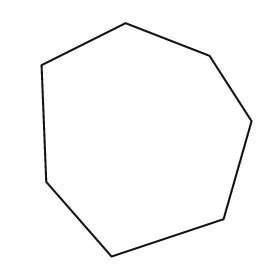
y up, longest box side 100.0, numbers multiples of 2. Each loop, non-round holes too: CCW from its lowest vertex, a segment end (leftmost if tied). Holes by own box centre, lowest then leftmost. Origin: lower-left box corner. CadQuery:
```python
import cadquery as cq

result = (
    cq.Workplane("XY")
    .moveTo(30.0, 0.0)
    .lineTo(78.0, 16.0)
    .lineTo(90.0, 58.0)
    .lineTo(72.0, 86.0)
    .lineTo(36.0, 100.0)
    .lineTo(0.0, 82.0)
    .lineTo(2.0, 32.0)
    .close()
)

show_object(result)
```